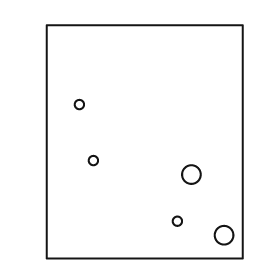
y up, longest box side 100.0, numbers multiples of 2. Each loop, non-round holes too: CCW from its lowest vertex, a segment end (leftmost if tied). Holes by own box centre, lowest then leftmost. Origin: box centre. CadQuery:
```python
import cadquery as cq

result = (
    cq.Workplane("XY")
    .moveTo(-42.0, -50.0)
    .lineTo(42.0, -50.0)
    .lineTo(42.0, 50.0)
    .lineTo(-42.0, 50.0)
    .close()
    .moveTo(34.0, -40.0)
    .circle(4.0)
    .moveTo(14.0, -34.0)
    .circle(2.0)
    .moveTo(20.0, -14.0)
    .circle(4.0)
    .moveTo(-22.0, -8.0)
    .circle(2.0)
    .moveTo(-28.0, 16.0)
    .circle(2.0)
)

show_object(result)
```